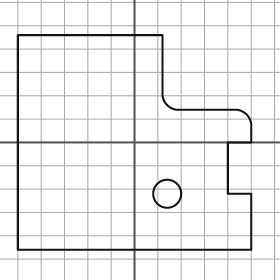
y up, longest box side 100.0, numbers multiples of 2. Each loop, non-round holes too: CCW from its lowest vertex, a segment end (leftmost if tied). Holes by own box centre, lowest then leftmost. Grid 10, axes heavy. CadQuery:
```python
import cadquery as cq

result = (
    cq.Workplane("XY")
    .moveTo(-50.0, -46.0)
    .lineTo(50.0, -46.0)
    .lineTo(50.0, -22.0)
    .lineTo(40.0, -22.0)
    .lineTo(40.0, 0.0)
    .lineTo(50.0, 0.0)
    .lineTo(50.0, 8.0)
    .threePointArc((48.0, 12.0), (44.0, 14.0))
    .lineTo(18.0, 14.0)
    .threePointArc((14.0, 16.0), (12.0, 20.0))
    .lineTo(12.0, 46.0)
    .lineTo(-50.0, 46.0)
    .close()
    .moveTo(14.0, -22.0)
    .circle(6.0)
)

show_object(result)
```